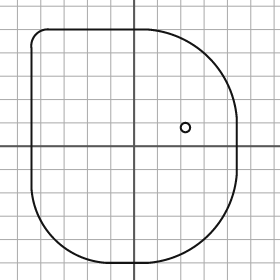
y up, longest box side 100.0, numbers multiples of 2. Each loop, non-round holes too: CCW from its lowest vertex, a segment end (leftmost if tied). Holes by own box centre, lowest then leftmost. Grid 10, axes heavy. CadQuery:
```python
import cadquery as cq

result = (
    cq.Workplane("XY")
    .moveTo(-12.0, -50.0)
    .lineTo(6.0, -50.0)
    .threePointArc((32.0, -38.0), (44.0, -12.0))
    .lineTo(44.0, 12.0)
    .threePointArc((32.0, 38.0), (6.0, 50.0))
    .lineTo(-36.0, 50.0)
    .threePointArc((-42.0, 48.0), (-44.0, 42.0))
    .lineTo(-44.0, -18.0)
    .threePointArc((-34.0, -40.0), (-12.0, -50.0))
    .close()
    .moveTo(22.0, 8.0)
    .circle(2.0)
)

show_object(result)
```